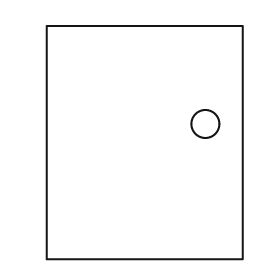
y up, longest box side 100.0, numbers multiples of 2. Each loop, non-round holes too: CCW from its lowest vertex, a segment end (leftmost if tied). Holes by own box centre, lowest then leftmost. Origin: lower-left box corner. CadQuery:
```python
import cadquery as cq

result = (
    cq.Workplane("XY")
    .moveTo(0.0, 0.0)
    .lineTo(84.0, 0.0)
    .lineTo(84.0, 100.0)
    .lineTo(0.0, 100.0)
    .close()
    .moveTo(68.0, 58.0)
    .circle(6.0)
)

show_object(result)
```